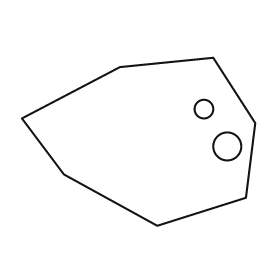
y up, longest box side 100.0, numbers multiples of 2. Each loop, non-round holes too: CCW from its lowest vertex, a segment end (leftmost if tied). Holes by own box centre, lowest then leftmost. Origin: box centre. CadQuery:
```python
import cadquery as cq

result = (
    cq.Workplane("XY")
    .moveTo(8.0, -36.0)
    .lineTo(46.0, -24.0)
    .lineTo(50.0, 8.0)
    .lineTo(32.0, 36.0)
    .lineTo(-8.0, 32.0)
    .lineTo(-50.0, 10.0)
    .lineTo(-32.0, -14.0)
    .close()
    .moveTo(38.0, -2.0)
    .circle(6.0)
    .moveTo(28.0, 14.0)
    .circle(4.0)
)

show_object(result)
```